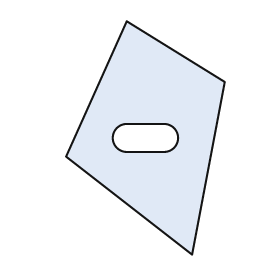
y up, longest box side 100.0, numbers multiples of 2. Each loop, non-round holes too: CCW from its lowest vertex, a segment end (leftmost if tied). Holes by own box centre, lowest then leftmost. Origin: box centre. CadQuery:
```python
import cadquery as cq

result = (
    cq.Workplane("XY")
    .moveTo(20.0, -50.0)
    .lineTo(34.0, 24.0)
    .lineTo(-8.0, 50.0)
    .lineTo(-34.0, -8.0)
    .close()
    .moveTo(-8.0, -6.0)
    .lineTo(8.0, -6.0)
    .threePointArc((14.0, 0.0), (8.0, 6.0))
    .lineTo(-8.0, 6.0)
    .threePointArc((-14.0, 0.0), (-8.0, -6.0))
    .close()
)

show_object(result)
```